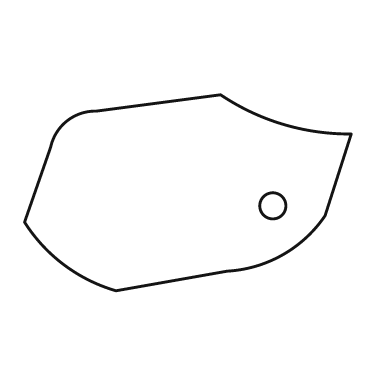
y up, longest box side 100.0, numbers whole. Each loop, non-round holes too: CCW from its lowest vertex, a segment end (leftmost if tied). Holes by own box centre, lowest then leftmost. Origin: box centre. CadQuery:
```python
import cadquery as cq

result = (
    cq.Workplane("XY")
    .moveTo(-22.0, -30.0)
    .lineTo(12.0, -24.0)
    .threePointArc((29.0, -19.0), (42.0, -7.0))
    .lineTo(50.0, 18.0)
    .threePointArc((29.0, 21.0), (10.0, 30.0))
    .lineTo(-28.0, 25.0)
    .threePointArc((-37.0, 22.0), (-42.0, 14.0))
    .lineTo(-50.0, -9.0)
    .threePointArc((-38.0, -22.0), (-22.0, -30.0))
    .close()
    .moveTo(26.0, -4.0)
    .circle(4.0)
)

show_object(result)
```